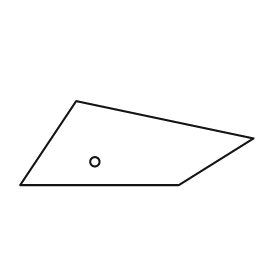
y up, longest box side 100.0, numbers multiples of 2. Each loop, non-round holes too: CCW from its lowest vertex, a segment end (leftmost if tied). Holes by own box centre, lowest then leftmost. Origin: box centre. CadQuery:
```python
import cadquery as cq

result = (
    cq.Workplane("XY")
    .moveTo(-50.0, -18.0)
    .lineTo(18.0, -18.0)
    .lineTo(50.0, 2.0)
    .lineTo(-26.0, 18.0)
    .close()
    .moveTo(-18.0, -8.0)
    .circle(2.0)
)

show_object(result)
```